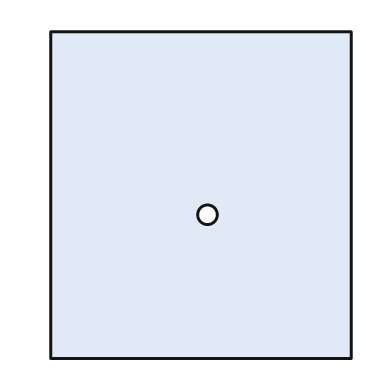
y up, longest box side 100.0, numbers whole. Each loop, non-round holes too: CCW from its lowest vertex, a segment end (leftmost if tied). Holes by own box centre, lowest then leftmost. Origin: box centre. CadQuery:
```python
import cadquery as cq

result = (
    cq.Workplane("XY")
    .moveTo(-46.0, -50.0)
    .lineTo(46.0, -50.0)
    .lineTo(46.0, 50.0)
    .lineTo(-46.0, 50.0)
    .close()
    .moveTo(2.0, -6.0)
    .circle(3.0)
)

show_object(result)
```